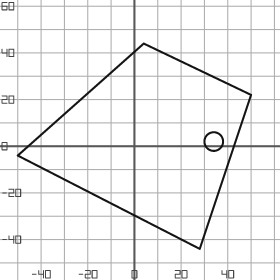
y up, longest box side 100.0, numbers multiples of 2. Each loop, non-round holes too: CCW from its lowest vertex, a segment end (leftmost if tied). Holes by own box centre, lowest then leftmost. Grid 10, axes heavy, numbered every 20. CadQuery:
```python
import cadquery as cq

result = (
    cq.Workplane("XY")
    .moveTo(28.0, -44.0)
    .lineTo(50.0, 22.0)
    .lineTo(4.0, 44.0)
    .lineTo(-50.0, -4.0)
    .close()
    .moveTo(34.0, 2.0)
    .circle(4.0)
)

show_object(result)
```